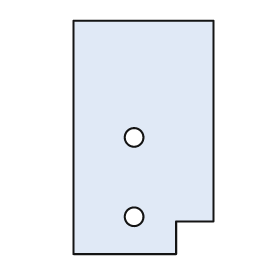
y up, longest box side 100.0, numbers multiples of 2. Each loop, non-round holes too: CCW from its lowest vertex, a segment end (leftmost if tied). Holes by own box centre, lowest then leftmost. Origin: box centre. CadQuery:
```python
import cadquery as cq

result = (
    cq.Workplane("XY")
    .moveTo(-30.0, -50.0)
    .lineTo(14.0, -50.0)
    .lineTo(14.0, -36.0)
    .lineTo(30.0, -36.0)
    .lineTo(30.0, 50.0)
    .lineTo(-30.0, 50.0)
    .close()
    .moveTo(-4.0, -34.0)
    .circle(4.0)
    .moveTo(-4.0, 0.0)
    .circle(4.0)
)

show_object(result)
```